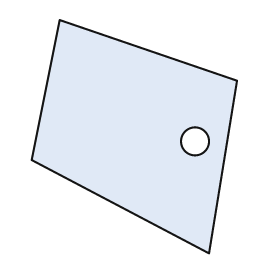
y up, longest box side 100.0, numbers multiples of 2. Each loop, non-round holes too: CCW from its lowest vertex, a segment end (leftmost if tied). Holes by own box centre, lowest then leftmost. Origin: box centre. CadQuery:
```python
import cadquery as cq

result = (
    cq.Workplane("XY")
    .moveTo(32.0, -50.0)
    .lineTo(44.0, 24.0)
    .lineTo(-32.0, 50.0)
    .lineTo(-44.0, -10.0)
    .close()
    .moveTo(26.0, -2.0)
    .circle(6.0)
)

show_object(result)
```